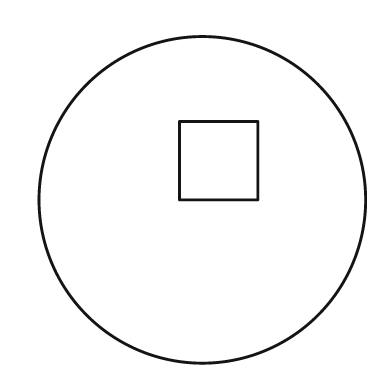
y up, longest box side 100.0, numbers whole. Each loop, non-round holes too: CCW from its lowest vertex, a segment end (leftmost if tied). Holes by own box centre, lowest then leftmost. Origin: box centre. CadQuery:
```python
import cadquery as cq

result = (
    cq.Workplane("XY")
    .moveTo(0.0, 0.0)
    .circle(50.0)
    .moveTo(-7.0, 0.0)
    .lineTo(17.0, 0.0)
    .lineTo(17.0, 24.0)
    .lineTo(-7.0, 24.0)
    .close()
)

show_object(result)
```